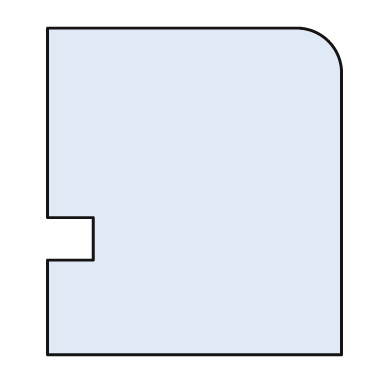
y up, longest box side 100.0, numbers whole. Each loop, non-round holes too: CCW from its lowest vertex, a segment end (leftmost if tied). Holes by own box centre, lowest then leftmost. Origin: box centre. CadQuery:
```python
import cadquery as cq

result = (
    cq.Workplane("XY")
    .moveTo(-45.0, -50.0)
    .lineTo(45.0, -50.0)
    .lineTo(45.0, 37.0)
    .threePointArc((41.0, 46.0), (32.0, 50.0))
    .lineTo(-45.0, 50.0)
    .lineTo(-45.0, -8.0)
    .lineTo(-31.0, -8.0)
    .lineTo(-31.0, -21.0)
    .lineTo(-45.0, -21.0)
    .close()
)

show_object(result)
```